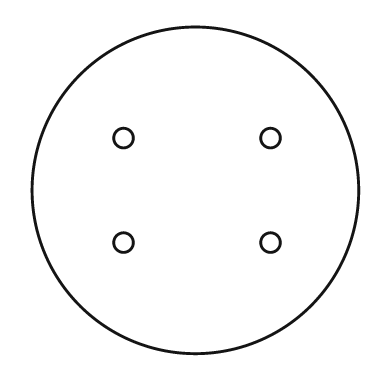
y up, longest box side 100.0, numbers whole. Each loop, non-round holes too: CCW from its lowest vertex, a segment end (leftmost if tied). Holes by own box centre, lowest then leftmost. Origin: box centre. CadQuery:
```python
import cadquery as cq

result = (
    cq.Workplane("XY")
    .moveTo(0.0, 0.0)
    .circle(50.0)
    .moveTo(-22.0, -16.0)
    .circle(3.0)
    .moveTo(23.0, -16.0)
    .circle(3.0)
    .moveTo(-22.0, 16.0)
    .circle(3.0)
    .moveTo(23.0, 16.0)
    .circle(3.0)
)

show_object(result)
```